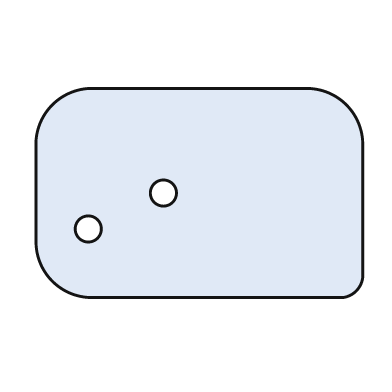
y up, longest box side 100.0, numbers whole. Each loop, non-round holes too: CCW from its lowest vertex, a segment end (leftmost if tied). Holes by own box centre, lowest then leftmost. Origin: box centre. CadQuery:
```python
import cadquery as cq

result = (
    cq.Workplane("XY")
    .moveTo(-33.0, -32.0)
    .lineTo(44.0, -32.0)
    .threePointArc((48.0, -30.0), (50.0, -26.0))
    .lineTo(50.0, 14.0)
    .threePointArc((45.0, 27.0), (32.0, 32.0))
    .lineTo(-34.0, 32.0)
    .threePointArc((-45.0, 27.0), (-50.0, 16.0))
    .lineTo(-50.0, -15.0)
    .threePointArc((-45.0, -27.0), (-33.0, -32.0))
    .close()
    .moveTo(-34.0, -11.0)
    .circle(4.0)
    .moveTo(-11.0, 0.0)
    .circle(4.0)
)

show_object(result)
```